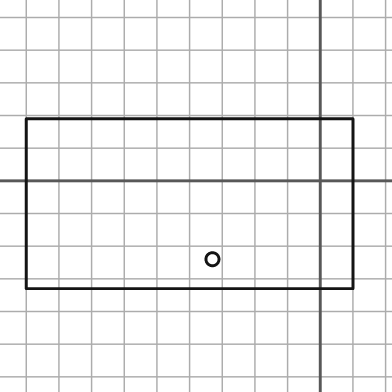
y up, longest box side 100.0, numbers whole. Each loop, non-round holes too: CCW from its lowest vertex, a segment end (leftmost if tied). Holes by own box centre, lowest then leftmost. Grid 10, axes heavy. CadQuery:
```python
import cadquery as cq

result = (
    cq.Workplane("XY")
    .moveTo(-90.0, -33.0)
    .lineTo(10.0, -33.0)
    .lineTo(10.0, 19.0)
    .lineTo(-90.0, 19.0)
    .close()
    .moveTo(-33.0, -24.0)
    .circle(2.0)
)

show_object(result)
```